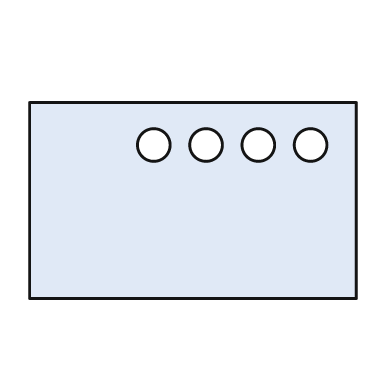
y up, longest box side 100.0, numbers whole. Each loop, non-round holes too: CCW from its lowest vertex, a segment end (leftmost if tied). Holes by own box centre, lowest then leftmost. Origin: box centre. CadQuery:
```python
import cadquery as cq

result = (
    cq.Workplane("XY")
    .moveTo(-50.0, -30.0)
    .lineTo(50.0, -30.0)
    .lineTo(50.0, 30.0)
    .lineTo(-50.0, 30.0)
    .close()
    .moveTo(-12.0, 17.0)
    .circle(5.0)
    .moveTo(4.0, 17.0)
    .circle(5.0)
    .moveTo(20.0, 17.0)
    .circle(5.0)
    .moveTo(36.0, 17.0)
    .circle(5.0)
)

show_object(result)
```